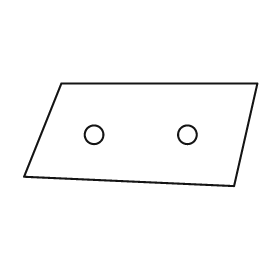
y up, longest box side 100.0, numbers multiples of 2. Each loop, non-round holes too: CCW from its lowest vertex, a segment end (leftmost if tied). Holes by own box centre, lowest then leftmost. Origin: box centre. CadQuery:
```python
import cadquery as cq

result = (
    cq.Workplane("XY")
    .moveTo(40.0, -22.0)
    .lineTo(50.0, 22.0)
    .lineTo(-34.0, 22.0)
    .lineTo(-50.0, -18.0)
    .close()
    .moveTo(-20.0, 0.0)
    .circle(4.0)
    .moveTo(20.0, 0.0)
    .circle(4.0)
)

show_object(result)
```